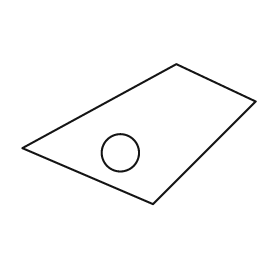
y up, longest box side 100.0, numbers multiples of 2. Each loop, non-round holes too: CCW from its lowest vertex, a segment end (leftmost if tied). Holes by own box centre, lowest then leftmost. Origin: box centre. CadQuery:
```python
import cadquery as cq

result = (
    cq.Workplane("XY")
    .moveTo(6.0, -30.0)
    .lineTo(50.0, 14.0)
    .lineTo(16.0, 30.0)
    .lineTo(-50.0, -6.0)
    .close()
    .moveTo(-8.0, -8.0)
    .circle(8.0)
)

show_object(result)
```